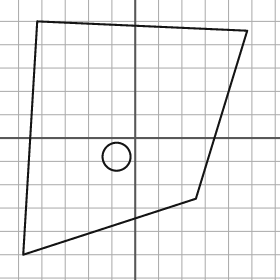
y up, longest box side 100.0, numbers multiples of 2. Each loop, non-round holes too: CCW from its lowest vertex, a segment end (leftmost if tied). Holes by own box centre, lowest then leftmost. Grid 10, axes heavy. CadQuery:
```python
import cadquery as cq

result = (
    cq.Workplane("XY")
    .moveTo(-48.0, -50.0)
    .lineTo(26.0, -26.0)
    .lineTo(48.0, 46.0)
    .lineTo(-42.0, 50.0)
    .close()
    .moveTo(-8.0, -8.0)
    .circle(6.0)
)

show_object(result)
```